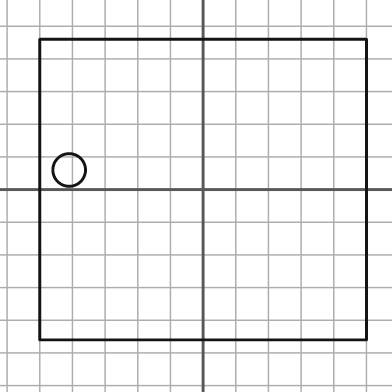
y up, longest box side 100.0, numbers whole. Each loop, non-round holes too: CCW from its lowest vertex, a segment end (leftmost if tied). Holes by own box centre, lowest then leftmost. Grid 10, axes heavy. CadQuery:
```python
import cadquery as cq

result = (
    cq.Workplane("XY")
    .moveTo(-50.0, -46.0)
    .lineTo(50.0, -46.0)
    .lineTo(50.0, 46.0)
    .lineTo(-50.0, 46.0)
    .close()
    .moveTo(-41.0, 6.0)
    .circle(5.0)
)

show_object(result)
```